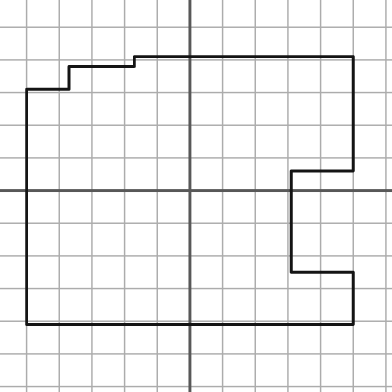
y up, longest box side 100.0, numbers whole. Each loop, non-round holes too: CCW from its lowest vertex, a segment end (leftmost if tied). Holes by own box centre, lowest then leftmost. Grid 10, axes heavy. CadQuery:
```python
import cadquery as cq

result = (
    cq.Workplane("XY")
    .moveTo(-50.0, -41.0)
    .lineTo(50.0, -41.0)
    .lineTo(50.0, -25.0)
    .lineTo(31.0, -25.0)
    .lineTo(31.0, 6.0)
    .lineTo(50.0, 6.0)
    .lineTo(50.0, 41.0)
    .lineTo(-17.0, 41.0)
    .lineTo(-17.0, 38.0)
    .lineTo(-37.0, 38.0)
    .lineTo(-37.0, 31.0)
    .lineTo(-50.0, 31.0)
    .close()
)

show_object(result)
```